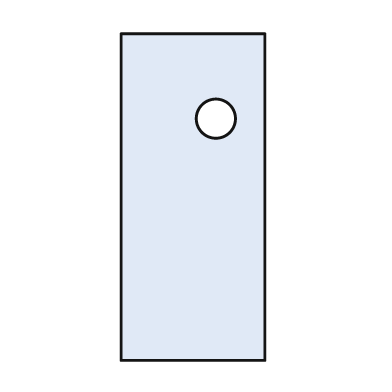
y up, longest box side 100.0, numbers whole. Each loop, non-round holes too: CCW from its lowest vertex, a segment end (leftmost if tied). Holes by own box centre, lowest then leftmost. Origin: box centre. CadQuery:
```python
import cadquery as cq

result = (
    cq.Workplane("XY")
    .moveTo(-22.0, -50.0)
    .lineTo(22.0, -50.0)
    .lineTo(22.0, 50.0)
    .lineTo(-22.0, 50.0)
    .close()
    .moveTo(7.0, 24.0)
    .circle(6.0)
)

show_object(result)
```